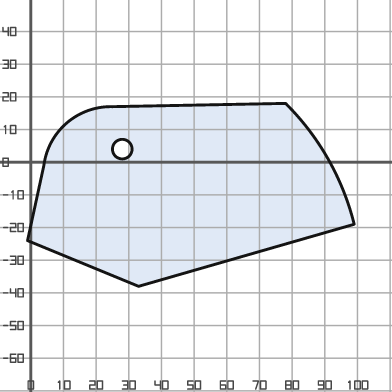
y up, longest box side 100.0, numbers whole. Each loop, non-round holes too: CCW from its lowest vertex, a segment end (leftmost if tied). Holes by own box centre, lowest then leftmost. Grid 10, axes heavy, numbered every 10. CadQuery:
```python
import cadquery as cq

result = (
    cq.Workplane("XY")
    .moveTo(33.0, -38.0)
    .lineTo(99.0, -19.0)
    .threePointArc((91.0, 1.0), (78.0, 18.0))
    .lineTo(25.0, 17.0)
    .threePointArc((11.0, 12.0), (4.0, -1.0))
    .lineTo(-1.0, -24.0)
    .close()
    .moveTo(28.0, 4.0)
    .circle(3.0)
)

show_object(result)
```